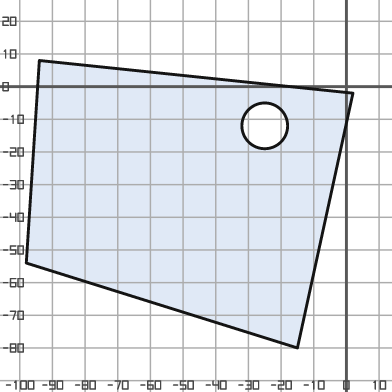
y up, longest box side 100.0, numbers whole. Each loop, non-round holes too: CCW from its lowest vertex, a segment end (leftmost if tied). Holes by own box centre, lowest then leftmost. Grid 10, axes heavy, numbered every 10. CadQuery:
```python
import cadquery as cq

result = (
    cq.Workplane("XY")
    .moveTo(-15.0, -80.0)
    .lineTo(2.0, -2.0)
    .lineTo(-94.0, 8.0)
    .lineTo(-98.0, -54.0)
    .close()
    .moveTo(-25.0, -12.0)
    .circle(7.0)
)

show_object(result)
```